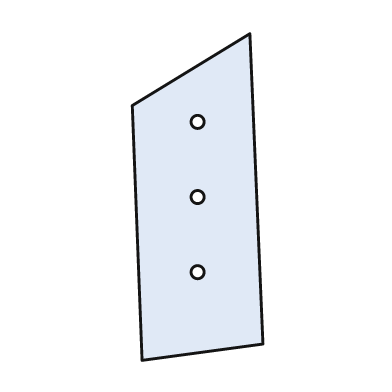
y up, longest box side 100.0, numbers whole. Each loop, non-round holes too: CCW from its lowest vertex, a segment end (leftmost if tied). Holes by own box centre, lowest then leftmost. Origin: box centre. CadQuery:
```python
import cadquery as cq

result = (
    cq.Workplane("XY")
    .moveTo(-17.0, -50.0)
    .lineTo(20.0, -45.0)
    .lineTo(16.0, 50.0)
    .lineTo(-20.0, 28.0)
    .close()
    .moveTo(0.0, -23.0)
    .circle(2.0)
    .moveTo(0.0, 0.0)
    .circle(2.0)
    .moveTo(0.0, 23.0)
    .circle(2.0)
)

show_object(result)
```